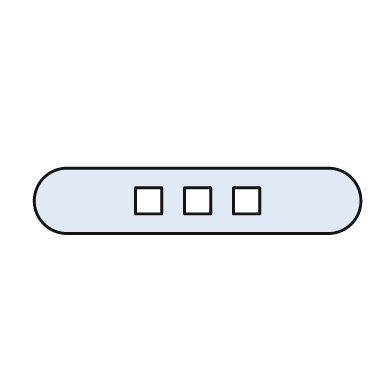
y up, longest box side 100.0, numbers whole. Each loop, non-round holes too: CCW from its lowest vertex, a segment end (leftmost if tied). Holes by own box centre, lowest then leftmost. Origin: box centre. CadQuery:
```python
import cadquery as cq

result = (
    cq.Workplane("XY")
    .moveTo(-40.0, -10.0)
    .lineTo(40.0, -10.0)
    .threePointArc((50.0, 0.0), (40.0, 10.0))
    .lineTo(-40.0, 10.0)
    .threePointArc((-50.0, 0.0), (-40.0, -10.0))
    .close()
    .moveTo(-19.0, -4.0)
    .lineTo(-11.0, -4.0)
    .lineTo(-11.0, 4.0)
    .lineTo(-19.0, 4.0)
    .close()
    .moveTo(-4.0, -4.0)
    .lineTo(4.0, -4.0)
    .lineTo(4.0, 4.0)
    .lineTo(-4.0, 4.0)
    .close()
    .moveTo(11.0, -4.0)
    .lineTo(19.0, -4.0)
    .lineTo(19.0, 4.0)
    .lineTo(11.0, 4.0)
    .close()
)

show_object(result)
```